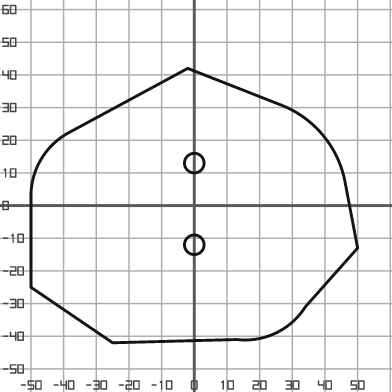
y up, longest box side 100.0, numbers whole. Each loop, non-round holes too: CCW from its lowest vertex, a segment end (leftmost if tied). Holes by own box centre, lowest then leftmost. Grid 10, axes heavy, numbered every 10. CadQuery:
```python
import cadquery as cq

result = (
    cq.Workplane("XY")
    .moveTo(-25.0, -42.0)
    .lineTo(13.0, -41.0)
    .threePointArc((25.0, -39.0), (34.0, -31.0))
    .lineTo(50.0, -13.0)
    .lineTo(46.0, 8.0)
    .threePointArc((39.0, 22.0), (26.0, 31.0))
    .lineTo(-2.0, 42.0)
    .lineTo(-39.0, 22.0)
    .threePointArc((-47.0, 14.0), (-50.0, 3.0))
    .lineTo(-50.0, -25.0)
    .close()
    .moveTo(0.0, -12.0)
    .circle(3.0)
    .moveTo(0.0, 13.0)
    .circle(3.0)
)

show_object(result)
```